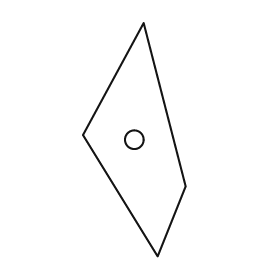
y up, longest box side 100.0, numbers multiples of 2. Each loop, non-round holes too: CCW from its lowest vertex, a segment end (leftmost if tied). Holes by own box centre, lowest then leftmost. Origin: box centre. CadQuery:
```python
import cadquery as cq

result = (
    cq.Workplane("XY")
    .moveTo(10.0, -50.0)
    .lineTo(22.0, -20.0)
    .lineTo(4.0, 50.0)
    .lineTo(-22.0, 2.0)
    .close()
    .moveTo(0.0, 0.0)
    .circle(4.0)
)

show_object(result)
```